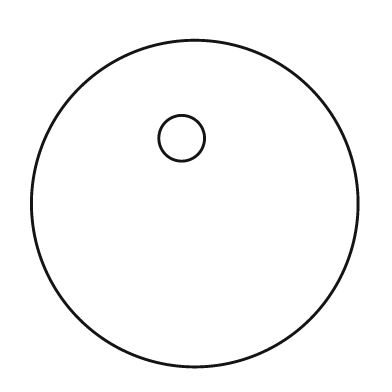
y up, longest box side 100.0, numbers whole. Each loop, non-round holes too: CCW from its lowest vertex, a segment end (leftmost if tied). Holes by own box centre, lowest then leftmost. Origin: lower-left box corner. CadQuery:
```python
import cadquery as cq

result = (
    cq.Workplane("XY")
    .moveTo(50.0, 50.0)
    .circle(50.0)
    .moveTo(46.0, 70.0)
    .circle(7.0)
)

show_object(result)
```